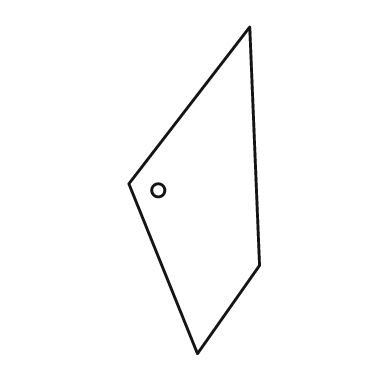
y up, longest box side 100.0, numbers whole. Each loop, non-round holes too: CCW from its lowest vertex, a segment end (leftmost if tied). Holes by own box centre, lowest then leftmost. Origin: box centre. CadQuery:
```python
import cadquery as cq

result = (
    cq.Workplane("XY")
    .moveTo(1.0, -50.0)
    .lineTo(20.0, -23.0)
    .lineTo(17.0, 50.0)
    .lineTo(-20.0, 2.0)
    .close()
    .moveTo(-11.0, 0.0)
    .circle(2.0)
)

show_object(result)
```